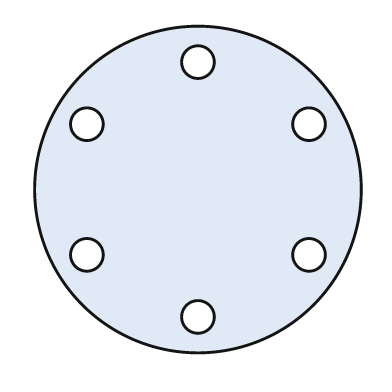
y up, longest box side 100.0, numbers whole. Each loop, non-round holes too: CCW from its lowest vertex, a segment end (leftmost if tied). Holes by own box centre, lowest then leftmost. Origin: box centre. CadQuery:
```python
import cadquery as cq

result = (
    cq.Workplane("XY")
    .moveTo(0.0, 0.0)
    .circle(50.0)
    .moveTo(0.0, -39.0)
    .circle(5.0)
    .moveTo(-34.0, -20.0)
    .circle(5.0)
    .moveTo(34.0, -20.0)
    .circle(5.0)
    .moveTo(-34.0, 20.0)
    .circle(5.0)
    .moveTo(34.0, 20.0)
    .circle(5.0)
    .moveTo(0.0, 39.0)
    .circle(5.0)
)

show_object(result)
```